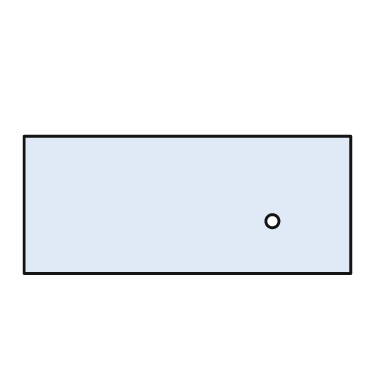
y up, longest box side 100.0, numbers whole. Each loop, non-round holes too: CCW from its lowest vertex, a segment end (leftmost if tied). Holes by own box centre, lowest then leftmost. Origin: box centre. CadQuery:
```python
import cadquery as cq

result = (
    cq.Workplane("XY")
    .moveTo(-50.0, -21.0)
    .lineTo(50.0, -21.0)
    .lineTo(50.0, 21.0)
    .lineTo(-50.0, 21.0)
    .close()
    .moveTo(26.0, -5.0)
    .circle(2.0)
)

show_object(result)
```